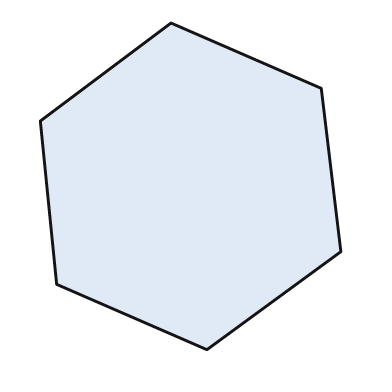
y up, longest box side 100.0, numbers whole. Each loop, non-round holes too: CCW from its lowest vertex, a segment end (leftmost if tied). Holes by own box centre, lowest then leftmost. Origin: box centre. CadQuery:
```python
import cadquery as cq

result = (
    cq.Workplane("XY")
    .moveTo(5.0, -50.0)
    .lineTo(46.0, -20.0)
    .lineTo(40.0, 30.0)
    .lineTo(-6.0, 50.0)
    .lineTo(-46.0, 20.0)
    .lineTo(-41.0, -30.0)
    .close()
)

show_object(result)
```